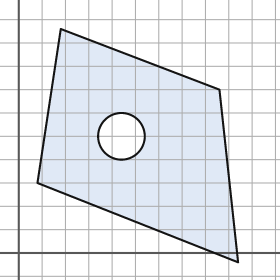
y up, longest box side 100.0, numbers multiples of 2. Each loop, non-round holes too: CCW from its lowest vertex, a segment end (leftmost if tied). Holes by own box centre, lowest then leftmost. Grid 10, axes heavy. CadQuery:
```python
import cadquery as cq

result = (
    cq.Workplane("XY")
    .moveTo(94.0, -4.0)
    .lineTo(86.0, 70.0)
    .lineTo(18.0, 96.0)
    .lineTo(8.0, 30.0)
    .close()
    .moveTo(44.0, 50.0)
    .circle(10.0)
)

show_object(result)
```